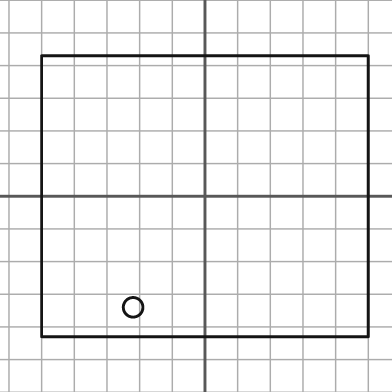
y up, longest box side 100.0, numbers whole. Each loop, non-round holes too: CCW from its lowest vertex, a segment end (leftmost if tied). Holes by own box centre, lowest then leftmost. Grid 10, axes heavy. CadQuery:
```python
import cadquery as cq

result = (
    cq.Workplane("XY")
    .moveTo(-50.0, -43.0)
    .lineTo(50.0, -43.0)
    .lineTo(50.0, 43.0)
    .lineTo(-50.0, 43.0)
    .close()
    .moveTo(-22.0, -34.0)
    .circle(3.0)
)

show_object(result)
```